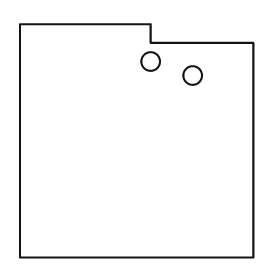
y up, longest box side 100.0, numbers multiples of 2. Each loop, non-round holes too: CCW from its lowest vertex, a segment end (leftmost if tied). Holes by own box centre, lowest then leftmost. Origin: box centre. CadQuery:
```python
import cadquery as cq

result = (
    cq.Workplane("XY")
    .moveTo(-50.0, -50.0)
    .lineTo(50.0, -50.0)
    .lineTo(50.0, 42.0)
    .lineTo(6.0, 42.0)
    .lineTo(6.0, 50.0)
    .lineTo(-50.0, 50.0)
    .close()
    .moveTo(24.0, 28.0)
    .circle(4.0)
    .moveTo(6.0, 34.0)
    .circle(4.0)
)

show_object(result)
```